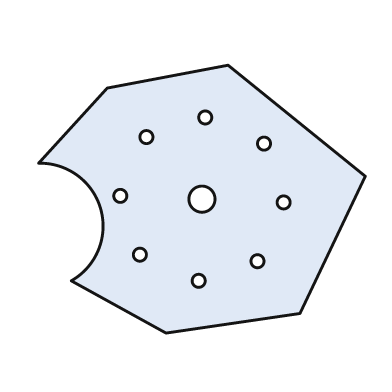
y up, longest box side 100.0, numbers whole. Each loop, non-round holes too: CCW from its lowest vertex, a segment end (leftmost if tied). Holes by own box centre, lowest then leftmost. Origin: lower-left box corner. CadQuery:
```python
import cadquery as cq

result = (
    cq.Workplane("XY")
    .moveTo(39.0, 0.0)
    .lineTo(80.0, 6.0)
    .lineTo(100.0, 48.0)
    .lineTo(58.0, 82.0)
    .lineTo(21.0, 75.0)
    .lineTo(0.0, 52.0)
    .threePointArc((19.0, 38.0), (10.0, 16.0))
    .close()
    .moveTo(49.0, 16.0)
    .circle(2.0)
    .moveTo(67.0, 22.0)
    .circle(2.0)
    .moveTo(31.0, 24.0)
    .circle(2.0)
    .moveTo(75.0, 40.0)
    .circle(2.0)
    .moveTo(50.0, 41.0)
    .circle(4.0)
    .moveTo(25.0, 42.0)
    .circle(2.0)
    .moveTo(69.0, 58.0)
    .circle(2.0)
    .moveTo(33.0, 60.0)
    .circle(2.0)
    .moveTo(51.0, 66.0)
    .circle(2.0)
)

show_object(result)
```